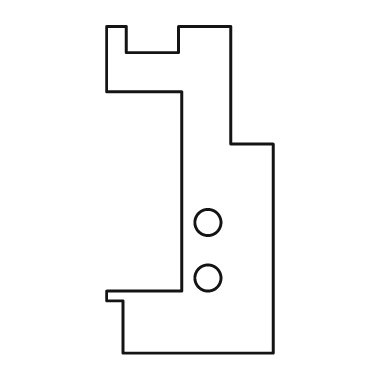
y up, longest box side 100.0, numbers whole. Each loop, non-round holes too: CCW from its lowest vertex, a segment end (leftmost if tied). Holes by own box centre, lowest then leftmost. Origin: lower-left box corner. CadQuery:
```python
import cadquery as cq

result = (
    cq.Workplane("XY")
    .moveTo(5.0, 0.0)
    .lineTo(51.0, 0.0)
    .lineTo(51.0, 64.0)
    .lineTo(38.0, 64.0)
    .lineTo(38.0, 100.0)
    .lineTo(22.0, 100.0)
    .lineTo(22.0, 92.0)
    .lineTo(6.0, 92.0)
    .lineTo(6.0, 100.0)
    .lineTo(0.0, 100.0)
    .lineTo(0.0, 80.0)
    .lineTo(23.0, 80.0)
    .lineTo(23.0, 19.0)
    .lineTo(0.0, 19.0)
    .lineTo(0.0, 16.0)
    .lineTo(5.0, 16.0)
    .close()
    .moveTo(31.0, 23.0)
    .circle(4.0)
    .moveTo(31.0, 40.0)
    .circle(4.0)
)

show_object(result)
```